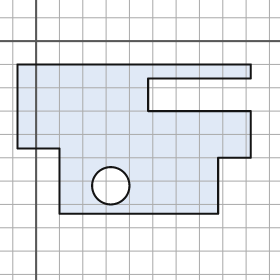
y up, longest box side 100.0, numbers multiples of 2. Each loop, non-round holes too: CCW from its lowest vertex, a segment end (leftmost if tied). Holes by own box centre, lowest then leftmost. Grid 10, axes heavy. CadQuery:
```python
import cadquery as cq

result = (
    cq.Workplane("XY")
    .moveTo(10.0, -74.0)
    .lineTo(78.0, -74.0)
    .lineTo(78.0, -50.0)
    .lineTo(92.0, -50.0)
    .lineTo(92.0, -30.0)
    .lineTo(48.0, -30.0)
    .lineTo(48.0, -16.0)
    .lineTo(92.0, -16.0)
    .lineTo(92.0, -10.0)
    .lineTo(-8.0, -10.0)
    .lineTo(-8.0, -46.0)
    .lineTo(10.0, -46.0)
    .close()
    .moveTo(32.0, -62.0)
    .circle(8.0)
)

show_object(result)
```